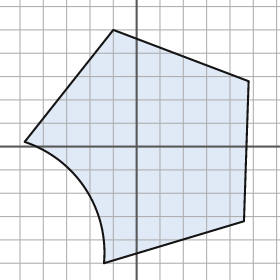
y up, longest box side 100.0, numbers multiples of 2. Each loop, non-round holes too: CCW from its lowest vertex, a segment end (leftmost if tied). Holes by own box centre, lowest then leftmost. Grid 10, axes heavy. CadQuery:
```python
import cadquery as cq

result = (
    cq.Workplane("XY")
    .moveTo(-14.0, -50.0)
    .lineTo(46.0, -32.0)
    .lineTo(48.0, 28.0)
    .lineTo(-10.0, 50.0)
    .lineTo(-48.0, 2.0)
    .threePointArc((-22.0, -18.0), (-14.0, -50.0))
    .close()
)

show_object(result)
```